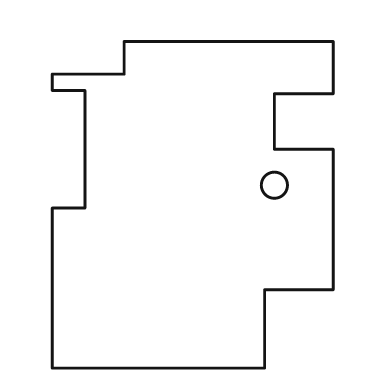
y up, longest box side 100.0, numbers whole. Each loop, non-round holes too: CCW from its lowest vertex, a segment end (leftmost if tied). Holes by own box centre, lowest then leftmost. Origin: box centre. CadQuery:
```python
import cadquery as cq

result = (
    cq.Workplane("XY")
    .moveTo(-43.0, -50.0)
    .lineTo(22.0, -50.0)
    .lineTo(22.0, -26.0)
    .lineTo(43.0, -26.0)
    .lineTo(43.0, 17.0)
    .lineTo(25.0, 17.0)
    .lineTo(25.0, 34.0)
    .lineTo(43.0, 34.0)
    .lineTo(43.0, 50.0)
    .lineTo(-21.0, 50.0)
    .lineTo(-21.0, 40.0)
    .lineTo(-43.0, 40.0)
    .lineTo(-43.0, 35.0)
    .lineTo(-33.0, 35.0)
    .lineTo(-33.0, -1.0)
    .lineTo(-43.0, -1.0)
    .close()
    .moveTo(25.0, 6.0)
    .circle(4.0)
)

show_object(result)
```